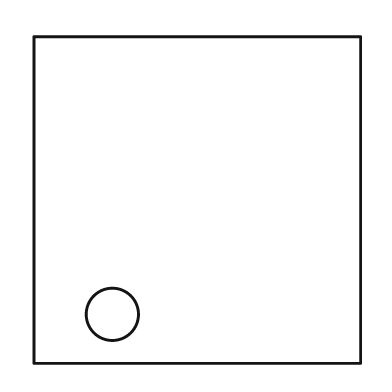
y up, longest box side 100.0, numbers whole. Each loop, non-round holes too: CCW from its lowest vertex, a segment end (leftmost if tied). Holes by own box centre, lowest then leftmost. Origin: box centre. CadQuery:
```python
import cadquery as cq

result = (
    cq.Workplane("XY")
    .moveTo(-50.0, -50.0)
    .lineTo(50.0, -50.0)
    .lineTo(50.0, 50.0)
    .lineTo(-50.0, 50.0)
    .close()
    .moveTo(-26.0, -35.0)
    .circle(8.0)
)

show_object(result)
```